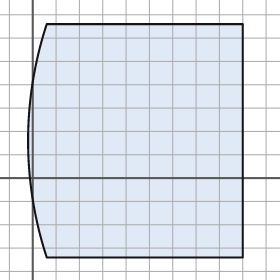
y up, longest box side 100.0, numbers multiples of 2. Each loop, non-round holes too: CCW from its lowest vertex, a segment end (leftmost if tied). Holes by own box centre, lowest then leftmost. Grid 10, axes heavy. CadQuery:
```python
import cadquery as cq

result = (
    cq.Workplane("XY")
    .moveTo(6.0, -34.0)
    .lineTo(90.0, -34.0)
    .lineTo(90.0, 66.0)
    .lineTo(6.0, 66.0)
    .threePointArc((-2.0, 16.0), (6.0, -34.0))
    .close()
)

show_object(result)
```